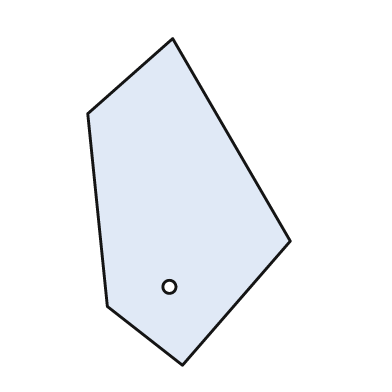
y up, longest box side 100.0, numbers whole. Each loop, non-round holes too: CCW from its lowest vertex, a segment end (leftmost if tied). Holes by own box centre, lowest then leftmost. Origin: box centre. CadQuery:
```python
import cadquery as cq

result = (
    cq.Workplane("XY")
    .moveTo(-2.0, -50.0)
    .lineTo(31.0, -12.0)
    .lineTo(-5.0, 50.0)
    .lineTo(-31.0, 27.0)
    .lineTo(-25.0, -32.0)
    .close()
    .moveTo(-6.0, -26.0)
    .circle(2.0)
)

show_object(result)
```